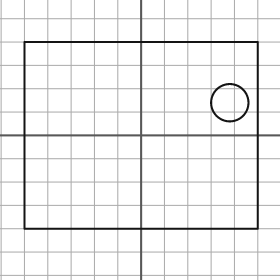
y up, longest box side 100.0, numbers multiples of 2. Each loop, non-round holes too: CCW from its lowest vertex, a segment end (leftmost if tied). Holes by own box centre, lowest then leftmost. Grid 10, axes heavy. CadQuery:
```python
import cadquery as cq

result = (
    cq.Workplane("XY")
    .moveTo(-50.0, -40.0)
    .lineTo(50.0, -40.0)
    .lineTo(50.0, 40.0)
    .lineTo(-50.0, 40.0)
    .close()
    .moveTo(38.0, 14.0)
    .circle(8.0)
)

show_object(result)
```